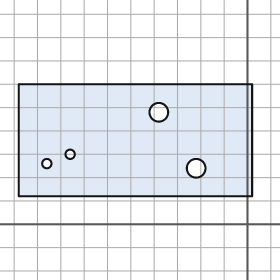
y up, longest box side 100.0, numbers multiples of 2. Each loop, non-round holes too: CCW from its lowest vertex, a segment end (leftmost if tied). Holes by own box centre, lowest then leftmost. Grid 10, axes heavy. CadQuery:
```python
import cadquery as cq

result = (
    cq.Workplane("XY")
    .moveTo(-98.0, 12.0)
    .lineTo(2.0, 12.0)
    .lineTo(2.0, 60.0)
    .lineTo(-98.0, 60.0)
    .close()
    .moveTo(-22.0, 24.0)
    .circle(4.0)
    .moveTo(-86.0, 26.0)
    .circle(2.0)
    .moveTo(-76.0, 30.0)
    .circle(2.0)
    .moveTo(-38.0, 48.0)
    .circle(4.0)
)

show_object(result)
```